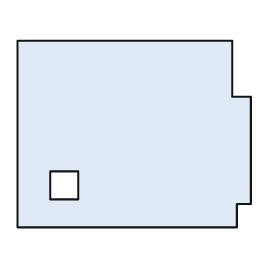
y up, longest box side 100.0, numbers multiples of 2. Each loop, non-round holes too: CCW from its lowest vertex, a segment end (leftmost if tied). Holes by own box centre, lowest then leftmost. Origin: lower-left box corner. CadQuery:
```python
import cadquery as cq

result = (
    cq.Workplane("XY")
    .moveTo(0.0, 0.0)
    .lineTo(94.0, 0.0)
    .lineTo(94.0, 10.0)
    .lineTo(100.0, 10.0)
    .lineTo(100.0, 56.0)
    .lineTo(92.0, 56.0)
    .lineTo(92.0, 80.0)
    .lineTo(0.0, 80.0)
    .close()
    .moveTo(14.0, 12.0)
    .lineTo(26.0, 12.0)
    .lineTo(26.0, 24.0)
    .lineTo(14.0, 24.0)
    .close()
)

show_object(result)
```